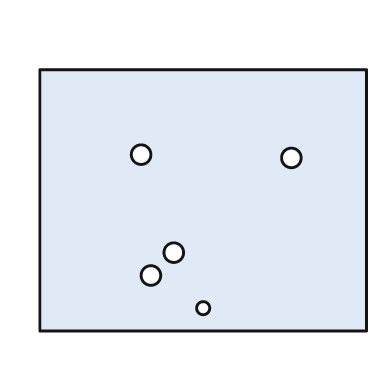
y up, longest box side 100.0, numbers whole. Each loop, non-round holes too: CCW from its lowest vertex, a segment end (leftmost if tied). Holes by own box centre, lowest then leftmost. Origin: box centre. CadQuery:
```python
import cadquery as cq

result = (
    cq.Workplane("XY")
    .moveTo(-50.0, -40.0)
    .lineTo(50.0, -40.0)
    .lineTo(50.0, 40.0)
    .lineTo(-50.0, 40.0)
    .close()
    .moveTo(0.0, -33.0)
    .circle(2.0)
    .moveTo(-16.0, -23.0)
    .circle(3.0)
    .moveTo(-9.0, -16.0)
    .circle(3.0)
    .moveTo(27.0, 13.0)
    .circle(3.0)
    .moveTo(-19.0, 14.0)
    .circle(3.0)
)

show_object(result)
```